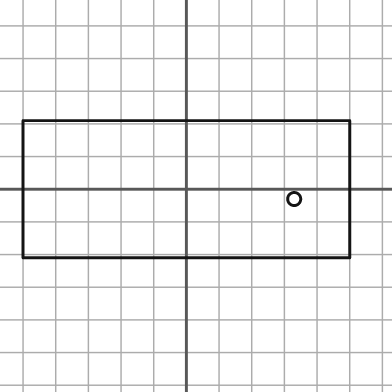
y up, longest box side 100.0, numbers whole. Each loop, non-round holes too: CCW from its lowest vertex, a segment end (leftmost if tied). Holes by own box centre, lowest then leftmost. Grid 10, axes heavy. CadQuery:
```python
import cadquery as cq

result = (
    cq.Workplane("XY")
    .moveTo(-50.0, -21.0)
    .lineTo(50.0, -21.0)
    .lineTo(50.0, 21.0)
    .lineTo(-50.0, 21.0)
    .close()
    .moveTo(33.0, -3.0)
    .circle(2.0)
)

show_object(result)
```